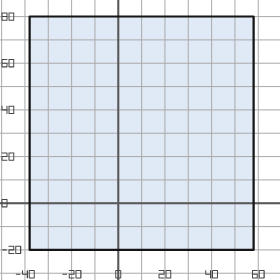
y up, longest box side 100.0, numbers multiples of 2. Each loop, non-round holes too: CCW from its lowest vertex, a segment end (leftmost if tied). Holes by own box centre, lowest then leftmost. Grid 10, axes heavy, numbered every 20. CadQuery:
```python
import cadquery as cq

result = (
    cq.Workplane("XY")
    .moveTo(-38.0, -20.0)
    .lineTo(58.0, -20.0)
    .lineTo(58.0, 80.0)
    .lineTo(-38.0, 80.0)
    .close()
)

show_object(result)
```